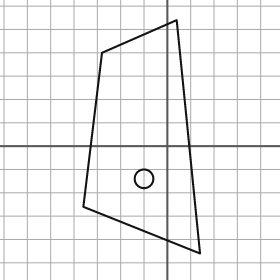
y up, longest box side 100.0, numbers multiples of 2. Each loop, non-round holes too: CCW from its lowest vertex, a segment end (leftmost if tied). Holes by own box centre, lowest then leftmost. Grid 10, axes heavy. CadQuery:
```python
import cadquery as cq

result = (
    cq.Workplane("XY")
    .moveTo(14.0, -46.0)
    .lineTo(4.0, 54.0)
    .lineTo(-28.0, 40.0)
    .lineTo(-36.0, -26.0)
    .close()
    .moveTo(-10.0, -14.0)
    .circle(4.0)
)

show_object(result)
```